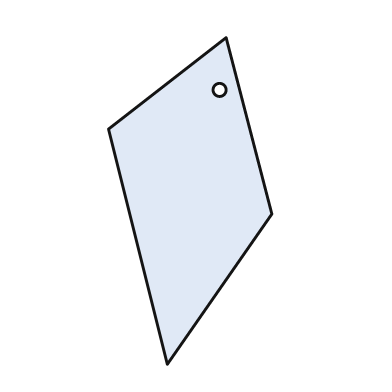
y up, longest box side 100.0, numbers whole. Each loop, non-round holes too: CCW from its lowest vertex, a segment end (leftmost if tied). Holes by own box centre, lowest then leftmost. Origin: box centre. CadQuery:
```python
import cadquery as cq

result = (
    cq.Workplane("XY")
    .moveTo(-7.0, -50.0)
    .lineTo(25.0, -4.0)
    .lineTo(11.0, 50.0)
    .lineTo(-25.0, 22.0)
    .close()
    .moveTo(9.0, 34.0)
    .circle(2.0)
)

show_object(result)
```